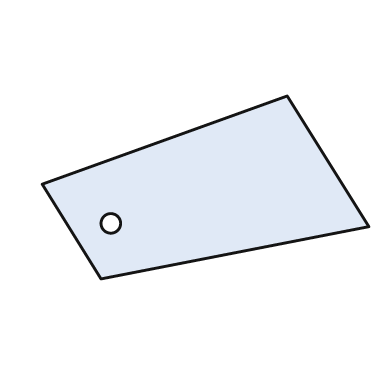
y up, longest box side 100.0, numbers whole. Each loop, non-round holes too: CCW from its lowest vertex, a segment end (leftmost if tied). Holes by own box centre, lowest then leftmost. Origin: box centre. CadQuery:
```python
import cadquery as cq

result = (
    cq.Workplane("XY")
    .moveTo(-32.0, -28.0)
    .lineTo(50.0, -12.0)
    .lineTo(25.0, 28.0)
    .lineTo(-50.0, 1.0)
    .close()
    .moveTo(-29.0, -11.0)
    .circle(3.0)
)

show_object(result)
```